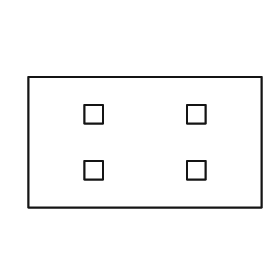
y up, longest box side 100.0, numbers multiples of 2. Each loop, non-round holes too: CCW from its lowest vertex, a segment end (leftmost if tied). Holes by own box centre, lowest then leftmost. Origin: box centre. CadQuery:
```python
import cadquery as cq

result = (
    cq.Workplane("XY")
    .moveTo(-50.0, -28.0)
    .lineTo(50.0, -28.0)
    .lineTo(50.0, 28.0)
    .lineTo(-50.0, 28.0)
    .close()
    .moveTo(-26.0, -16.0)
    .lineTo(-18.0, -16.0)
    .lineTo(-18.0, -8.0)
    .lineTo(-26.0, -8.0)
    .close()
    .moveTo(18.0, -16.0)
    .lineTo(26.0, -16.0)
    .lineTo(26.0, -8.0)
    .lineTo(18.0, -8.0)
    .close()
    .moveTo(-26.0, 8.0)
    .lineTo(-18.0, 8.0)
    .lineTo(-18.0, 16.0)
    .lineTo(-26.0, 16.0)
    .close()
    .moveTo(18.0, 8.0)
    .lineTo(26.0, 8.0)
    .lineTo(26.0, 16.0)
    .lineTo(18.0, 16.0)
    .close()
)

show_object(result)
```